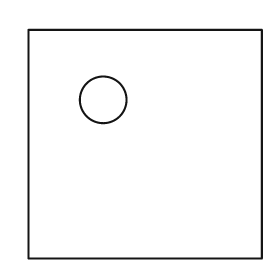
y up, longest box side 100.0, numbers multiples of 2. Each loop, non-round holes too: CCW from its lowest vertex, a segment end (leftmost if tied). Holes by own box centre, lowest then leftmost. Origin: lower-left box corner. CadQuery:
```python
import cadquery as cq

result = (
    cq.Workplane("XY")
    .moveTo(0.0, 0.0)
    .lineTo(100.0, 0.0)
    .lineTo(100.0, 98.0)
    .lineTo(0.0, 98.0)
    .close()
    .moveTo(32.0, 68.0)
    .circle(10.0)
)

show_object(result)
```